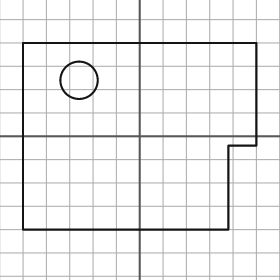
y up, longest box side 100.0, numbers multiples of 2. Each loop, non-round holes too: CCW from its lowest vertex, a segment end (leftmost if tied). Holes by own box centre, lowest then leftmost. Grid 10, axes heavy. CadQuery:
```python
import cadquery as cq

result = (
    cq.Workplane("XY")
    .moveTo(-50.0, -40.0)
    .lineTo(38.0, -40.0)
    .lineTo(38.0, -4.0)
    .lineTo(50.0, -4.0)
    .lineTo(50.0, 40.0)
    .lineTo(-50.0, 40.0)
    .close()
    .moveTo(-26.0, 24.0)
    .circle(8.0)
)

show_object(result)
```